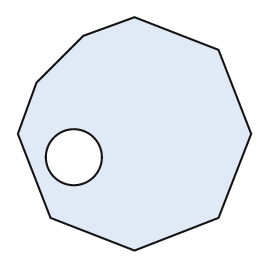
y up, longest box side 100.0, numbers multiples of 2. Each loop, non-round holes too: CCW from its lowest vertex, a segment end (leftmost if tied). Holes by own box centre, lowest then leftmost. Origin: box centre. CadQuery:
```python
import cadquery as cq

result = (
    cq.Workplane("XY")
    .moveTo(0.0, -50.0)
    .lineTo(36.0, -36.0)
    .lineTo(50.0, 0.0)
    .lineTo(36.0, 36.0)
    .lineTo(0.0, 50.0)
    .lineTo(-22.0, 42.0)
    .lineTo(-42.0, 22.0)
    .lineTo(-50.0, 0.0)
    .lineTo(-36.0, -36.0)
    .close()
    .moveTo(-26.0, -10.0)
    .circle(12.0)
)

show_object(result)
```